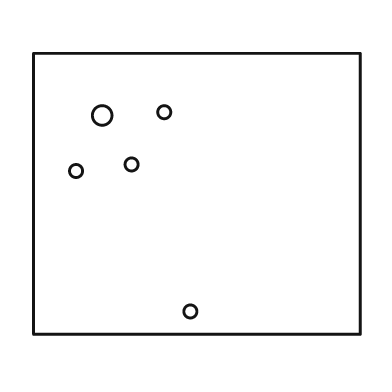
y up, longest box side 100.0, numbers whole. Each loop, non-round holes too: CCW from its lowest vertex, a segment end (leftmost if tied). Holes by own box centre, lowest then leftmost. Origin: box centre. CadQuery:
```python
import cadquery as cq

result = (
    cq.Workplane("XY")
    .moveTo(-50.0, -43.0)
    .lineTo(50.0, -43.0)
    .lineTo(50.0, 43.0)
    .lineTo(-50.0, 43.0)
    .close()
    .moveTo(-2.0, -36.0)
    .circle(2.0)
    .moveTo(-37.0, 7.0)
    .circle(2.0)
    .moveTo(-20.0, 9.0)
    .circle(2.0)
    .moveTo(-29.0, 24.0)
    .circle(3.0)
    .moveTo(-10.0, 25.0)
    .circle(2.0)
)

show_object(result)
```